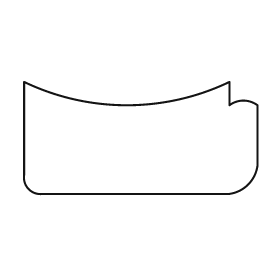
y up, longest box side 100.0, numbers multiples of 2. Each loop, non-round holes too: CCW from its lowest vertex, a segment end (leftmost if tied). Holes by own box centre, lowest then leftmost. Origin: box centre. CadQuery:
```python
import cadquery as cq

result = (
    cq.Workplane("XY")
    .moveTo(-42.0, -24.0)
    .lineTo(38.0, -24.0)
    .threePointArc((46.0, -20.0), (50.0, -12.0))
    .lineTo(50.0, 14.0)
    .threePointArc((44.0, 16.0), (38.0, 14.0))
    .lineTo(38.0, 24.0)
    .threePointArc((-6.0, 14.0), (-50.0, 24.0))
    .lineTo(-50.0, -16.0)
    .threePointArc((-48.0, -22.0), (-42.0, -24.0))
    .close()
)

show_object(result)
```